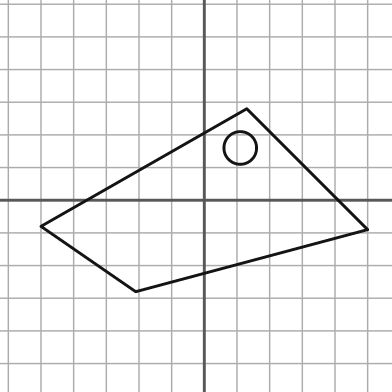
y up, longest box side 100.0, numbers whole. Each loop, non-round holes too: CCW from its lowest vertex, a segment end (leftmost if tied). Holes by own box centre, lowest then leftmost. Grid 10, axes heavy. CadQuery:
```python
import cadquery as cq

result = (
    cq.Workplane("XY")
    .moveTo(-21.0, -28.0)
    .lineTo(50.0, -9.0)
    .lineTo(13.0, 28.0)
    .lineTo(-50.0, -8.0)
    .close()
    .moveTo(11.0, 16.0)
    .circle(5.0)
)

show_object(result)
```